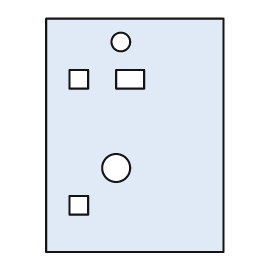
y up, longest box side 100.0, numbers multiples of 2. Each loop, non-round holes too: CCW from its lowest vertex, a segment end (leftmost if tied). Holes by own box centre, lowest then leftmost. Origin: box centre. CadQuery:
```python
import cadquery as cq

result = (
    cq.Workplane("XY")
    .moveTo(-38.0, -50.0)
    .lineTo(38.0, -50.0)
    .lineTo(38.0, 50.0)
    .lineTo(-38.0, 50.0)
    .close()
    .moveTo(-28.0, -34.0)
    .lineTo(-20.0, -34.0)
    .lineTo(-20.0, -26.0)
    .lineTo(-28.0, -26.0)
    .close()
    .moveTo(-8.0, -14.0)
    .circle(6.0)
    .moveTo(-28.0, 20.0)
    .lineTo(-20.0, 20.0)
    .lineTo(-20.0, 28.0)
    .lineTo(-28.0, 28.0)
    .close()
    .moveTo(-8.0, 20.0)
    .lineTo(4.0, 20.0)
    .lineTo(4.0, 28.0)
    .lineTo(-8.0, 28.0)
    .close()
    .moveTo(-6.0, 40.0)
    .circle(4.0)
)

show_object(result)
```